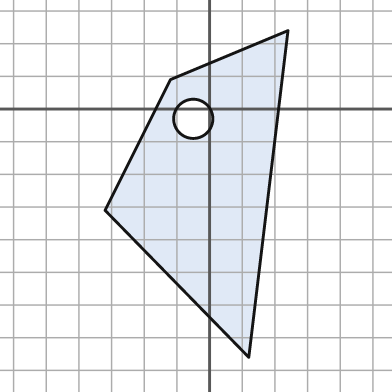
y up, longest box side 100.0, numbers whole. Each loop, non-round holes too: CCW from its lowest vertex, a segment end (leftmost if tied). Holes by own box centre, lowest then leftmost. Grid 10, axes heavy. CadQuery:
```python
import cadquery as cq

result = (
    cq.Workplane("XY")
    .moveTo(12.0, -76.0)
    .lineTo(24.0, 24.0)
    .lineTo(-12.0, 9.0)
    .lineTo(-32.0, -31.0)
    .close()
    .moveTo(-5.0, -3.0)
    .circle(6.0)
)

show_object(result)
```